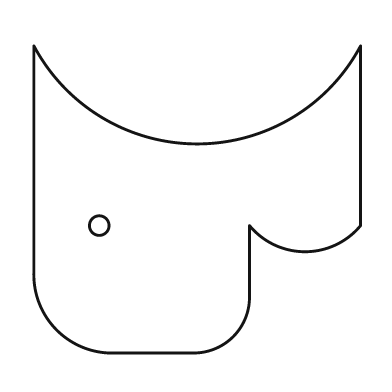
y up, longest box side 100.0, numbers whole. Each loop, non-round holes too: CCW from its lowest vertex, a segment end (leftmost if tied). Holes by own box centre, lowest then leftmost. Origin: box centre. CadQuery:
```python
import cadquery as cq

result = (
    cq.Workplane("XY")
    .moveTo(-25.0, -47.0)
    .lineTo(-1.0, -47.0)
    .threePointArc((11.0, -42.0), (16.0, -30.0))
    .lineTo(16.0, -8.0)
    .threePointArc((33.0, -16.0), (50.0, -8.0))
    .lineTo(50.0, 47.0)
    .threePointArc((0.0, 17.0), (-50.0, 47.0))
    .lineTo(-50.0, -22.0)
    .threePointArc((-43.0, -40.0), (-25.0, -47.0))
    .close()
    .moveTo(-30.0, -8.0)
    .circle(3.0)
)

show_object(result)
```